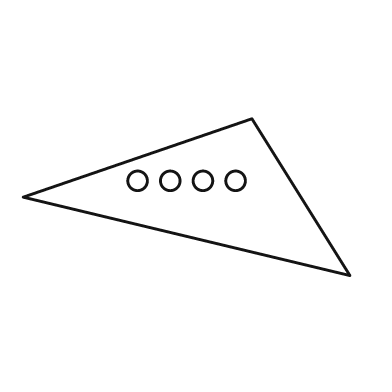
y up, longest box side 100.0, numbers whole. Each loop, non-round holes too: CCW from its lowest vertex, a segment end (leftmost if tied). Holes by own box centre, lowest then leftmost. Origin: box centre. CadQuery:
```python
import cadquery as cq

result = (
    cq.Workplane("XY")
    .moveTo(50.0, -24.0)
    .lineTo(20.0, 24.0)
    .lineTo(-50.0, 0.0)
    .close()
    .moveTo(-15.0, 5.0)
    .circle(3.0)
    .moveTo(-5.0, 5.0)
    .circle(3.0)
    .moveTo(5.0, 5.0)
    .circle(3.0)
    .moveTo(15.0, 5.0)
    .circle(3.0)
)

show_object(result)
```